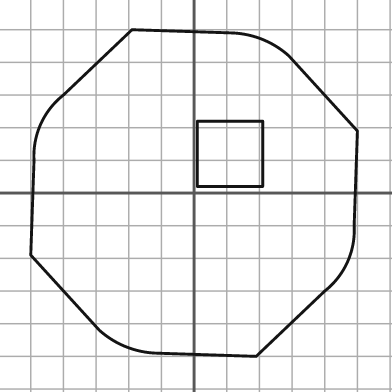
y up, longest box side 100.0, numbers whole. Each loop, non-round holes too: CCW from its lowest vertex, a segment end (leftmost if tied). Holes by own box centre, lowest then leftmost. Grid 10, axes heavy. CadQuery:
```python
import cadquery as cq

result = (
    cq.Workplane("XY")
    .moveTo(19.0, -50.0)
    .lineTo(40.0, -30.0)
    .threePointArc((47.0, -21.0), (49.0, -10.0))
    .lineTo(50.0, 19.0)
    .lineTo(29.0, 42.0)
    .threePointArc((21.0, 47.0), (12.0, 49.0))
    .lineTo(-19.0, 50.0)
    .lineTo(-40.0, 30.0)
    .threePointArc((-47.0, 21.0), (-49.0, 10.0))
    .lineTo(-50.0, -19.0)
    .lineTo(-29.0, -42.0)
    .threePointArc((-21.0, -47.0), (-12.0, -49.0))
    .close()
    .moveTo(1.0, 2.0)
    .lineTo(21.0, 2.0)
    .lineTo(21.0, 22.0)
    .lineTo(1.0, 22.0)
    .close()
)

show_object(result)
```